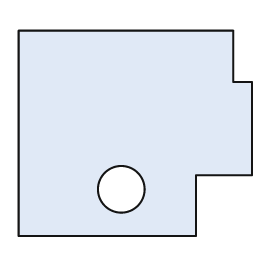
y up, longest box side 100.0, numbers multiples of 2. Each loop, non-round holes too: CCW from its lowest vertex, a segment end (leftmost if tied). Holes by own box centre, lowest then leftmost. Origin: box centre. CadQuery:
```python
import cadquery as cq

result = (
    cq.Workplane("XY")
    .moveTo(-50.0, -44.0)
    .lineTo(26.0, -44.0)
    .lineTo(26.0, -18.0)
    .lineTo(50.0, -18.0)
    .lineTo(50.0, 22.0)
    .lineTo(42.0, 22.0)
    .lineTo(42.0, 44.0)
    .lineTo(-50.0, 44.0)
    .close()
    .moveTo(-6.0, -24.0)
    .circle(10.0)
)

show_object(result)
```